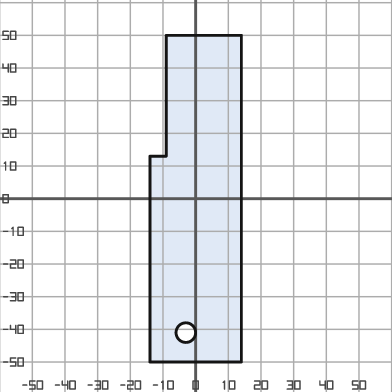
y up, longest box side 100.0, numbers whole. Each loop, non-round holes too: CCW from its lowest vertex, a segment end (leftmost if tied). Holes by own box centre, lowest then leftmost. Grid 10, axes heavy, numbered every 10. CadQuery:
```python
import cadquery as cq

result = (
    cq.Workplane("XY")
    .moveTo(-14.0, -50.0)
    .lineTo(14.0, -50.0)
    .lineTo(14.0, 50.0)
    .lineTo(-9.0, 50.0)
    .lineTo(-9.0, 13.0)
    .lineTo(-14.0, 13.0)
    .close()
    .moveTo(-3.0, -41.0)
    .circle(3.0)
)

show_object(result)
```